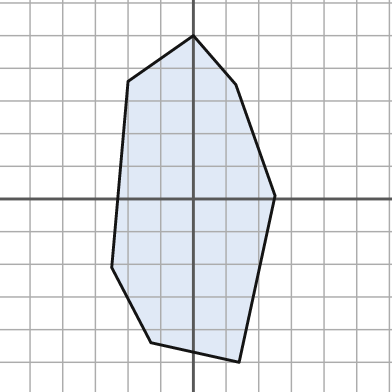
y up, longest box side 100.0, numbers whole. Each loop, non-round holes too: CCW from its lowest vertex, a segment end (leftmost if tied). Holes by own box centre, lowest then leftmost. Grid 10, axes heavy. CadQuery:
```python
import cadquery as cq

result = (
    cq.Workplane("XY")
    .moveTo(14.0, -50.0)
    .lineTo(25.0, 1.0)
    .lineTo(13.0, 35.0)
    .lineTo(0.0, 50.0)
    .lineTo(-20.0, 36.0)
    .lineTo(-25.0, -21.0)
    .lineTo(-13.0, -44.0)
    .close()
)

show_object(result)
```